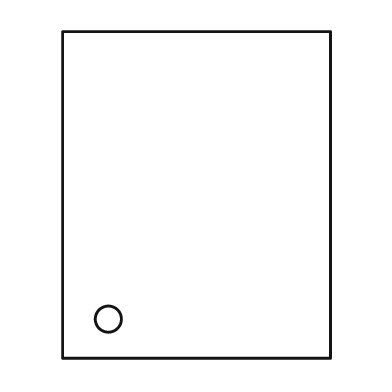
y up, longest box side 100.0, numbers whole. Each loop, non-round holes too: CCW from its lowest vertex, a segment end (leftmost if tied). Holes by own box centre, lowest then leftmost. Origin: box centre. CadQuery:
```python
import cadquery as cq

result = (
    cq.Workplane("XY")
    .moveTo(-41.0, -50.0)
    .lineTo(41.0, -50.0)
    .lineTo(41.0, 50.0)
    .lineTo(-41.0, 50.0)
    .close()
    .moveTo(-27.0, -38.0)
    .circle(4.0)
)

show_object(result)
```